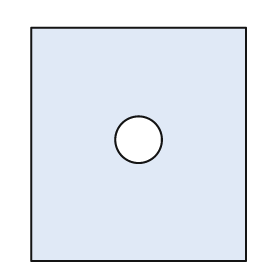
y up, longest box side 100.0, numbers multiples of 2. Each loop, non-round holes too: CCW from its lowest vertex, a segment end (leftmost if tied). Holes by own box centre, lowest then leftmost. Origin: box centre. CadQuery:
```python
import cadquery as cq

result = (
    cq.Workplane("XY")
    .moveTo(-46.0, -50.0)
    .lineTo(46.0, -50.0)
    .lineTo(46.0, 50.0)
    .lineTo(-46.0, 50.0)
    .close()
    .moveTo(0.0, 2.0)
    .circle(10.0)
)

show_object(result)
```